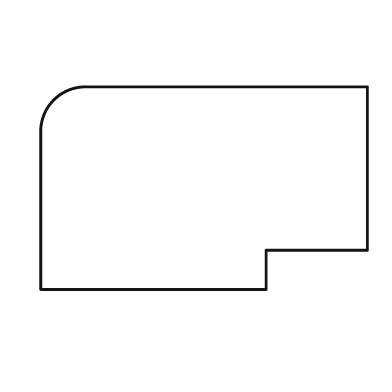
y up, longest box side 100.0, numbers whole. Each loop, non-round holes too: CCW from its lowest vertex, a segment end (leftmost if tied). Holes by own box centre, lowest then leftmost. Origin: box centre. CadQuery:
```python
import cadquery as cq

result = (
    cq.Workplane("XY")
    .moveTo(-50.0, -31.0)
    .lineTo(19.0, -31.0)
    .lineTo(19.0, -19.0)
    .lineTo(50.0, -19.0)
    .lineTo(50.0, 31.0)
    .lineTo(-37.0, 31.0)
    .threePointArc((-46.0, 27.0), (-50.0, 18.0))
    .close()
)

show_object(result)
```